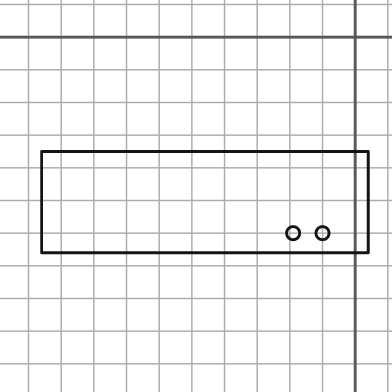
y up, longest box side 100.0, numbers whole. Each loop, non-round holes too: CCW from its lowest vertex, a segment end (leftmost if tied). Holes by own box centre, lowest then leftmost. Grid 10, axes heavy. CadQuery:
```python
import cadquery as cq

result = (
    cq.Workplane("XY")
    .moveTo(-96.0, -66.0)
    .lineTo(4.0, -66.0)
    .lineTo(4.0, -35.0)
    .lineTo(-96.0, -35.0)
    .close()
    .moveTo(-19.0, -60.0)
    .circle(2.0)
    .moveTo(-10.0, -60.0)
    .circle(2.0)
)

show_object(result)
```